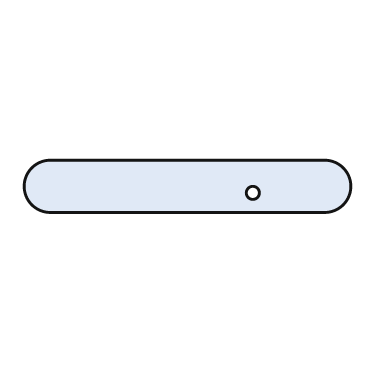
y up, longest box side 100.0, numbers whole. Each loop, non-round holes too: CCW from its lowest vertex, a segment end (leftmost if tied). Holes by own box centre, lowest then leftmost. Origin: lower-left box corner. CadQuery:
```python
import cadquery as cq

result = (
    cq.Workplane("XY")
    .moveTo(8.0, 0.0)
    .lineTo(92.0, 0.0)
    .threePointArc((100.0, 8.0), (92.0, 16.0))
    .lineTo(8.0, 16.0)
    .threePointArc((0.0, 8.0), (8.0, 0.0))
    .close()
    .moveTo(70.0, 6.0)
    .circle(2.0)
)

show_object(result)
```